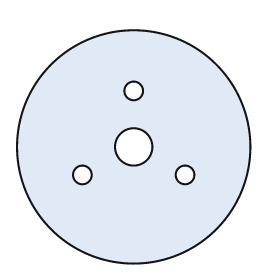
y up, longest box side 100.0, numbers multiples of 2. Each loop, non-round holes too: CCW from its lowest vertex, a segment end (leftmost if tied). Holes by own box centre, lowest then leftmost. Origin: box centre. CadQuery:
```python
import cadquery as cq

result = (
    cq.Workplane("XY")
    .moveTo(0.0, 0.0)
    .circle(50.0)
    .moveTo(-22.0, -12.0)
    .circle(4.0)
    .moveTo(22.0, -12.0)
    .circle(4.0)
    .moveTo(0.0, 0.0)
    .circle(8.0)
    .moveTo(0.0, 24.0)
    .circle(4.0)
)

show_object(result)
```